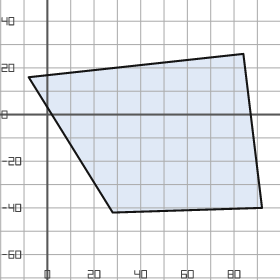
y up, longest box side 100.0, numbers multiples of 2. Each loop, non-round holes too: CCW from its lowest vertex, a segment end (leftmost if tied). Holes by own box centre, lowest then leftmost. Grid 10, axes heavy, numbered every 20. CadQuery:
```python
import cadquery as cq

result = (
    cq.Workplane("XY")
    .moveTo(28.0, -42.0)
    .lineTo(92.0, -40.0)
    .lineTo(84.0, 26.0)
    .lineTo(-8.0, 16.0)
    .close()
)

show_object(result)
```